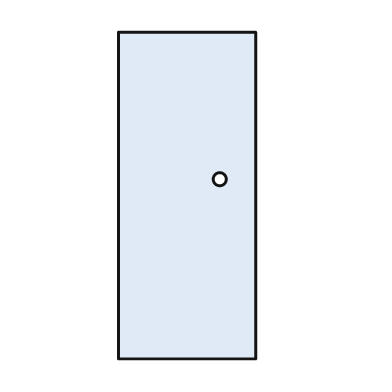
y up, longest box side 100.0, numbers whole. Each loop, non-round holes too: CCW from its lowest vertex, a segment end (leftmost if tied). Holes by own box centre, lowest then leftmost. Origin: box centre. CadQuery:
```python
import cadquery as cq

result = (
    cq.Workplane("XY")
    .moveTo(-21.0, -50.0)
    .lineTo(21.0, -50.0)
    .lineTo(21.0, 50.0)
    .lineTo(-21.0, 50.0)
    .close()
    .moveTo(10.0, 5.0)
    .circle(2.0)
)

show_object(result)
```